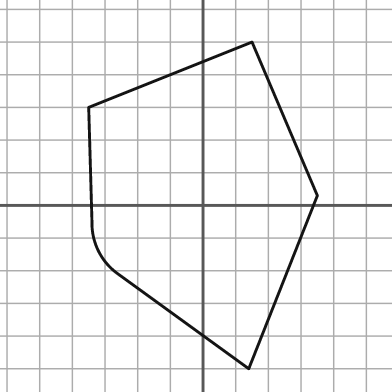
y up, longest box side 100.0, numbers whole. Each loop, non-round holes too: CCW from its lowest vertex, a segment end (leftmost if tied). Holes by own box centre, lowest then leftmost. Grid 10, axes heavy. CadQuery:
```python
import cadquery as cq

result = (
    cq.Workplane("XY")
    .moveTo(14.0, -50.0)
    .lineTo(35.0, 3.0)
    .lineTo(15.0, 50.0)
    .lineTo(-35.0, 30.0)
    .lineTo(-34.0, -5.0)
    .threePointArc((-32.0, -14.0), (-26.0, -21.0))
    .close()
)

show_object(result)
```